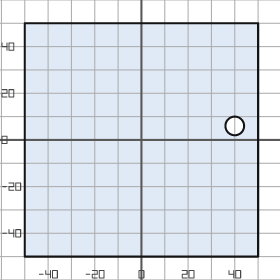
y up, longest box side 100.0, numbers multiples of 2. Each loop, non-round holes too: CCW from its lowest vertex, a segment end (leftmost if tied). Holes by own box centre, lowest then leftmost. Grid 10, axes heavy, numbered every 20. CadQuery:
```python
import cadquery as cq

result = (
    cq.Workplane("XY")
    .moveTo(-50.0, -50.0)
    .lineTo(50.0, -50.0)
    .lineTo(50.0, 50.0)
    .lineTo(-50.0, 50.0)
    .close()
    .moveTo(40.0, 6.0)
    .circle(4.0)
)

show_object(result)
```